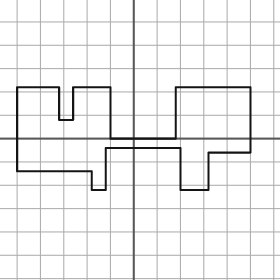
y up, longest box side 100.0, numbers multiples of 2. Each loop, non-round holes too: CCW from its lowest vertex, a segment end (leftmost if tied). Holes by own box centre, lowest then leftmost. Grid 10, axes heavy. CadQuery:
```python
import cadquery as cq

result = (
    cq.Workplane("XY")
    .moveTo(-18.0, -22.0)
    .lineTo(-12.0, -22.0)
    .lineTo(-12.0, -4.0)
    .lineTo(20.0, -4.0)
    .lineTo(20.0, -22.0)
    .lineTo(32.0, -22.0)
    .lineTo(32.0, -6.0)
    .lineTo(50.0, -6.0)
    .lineTo(50.0, 22.0)
    .lineTo(18.0, 22.0)
    .lineTo(18.0, 0.0)
    .lineTo(-10.0, 0.0)
    .lineTo(-10.0, 22.0)
    .lineTo(-26.0, 22.0)
    .lineTo(-26.0, 8.0)
    .lineTo(-32.0, 8.0)
    .lineTo(-32.0, 22.0)
    .lineTo(-50.0, 22.0)
    .lineTo(-50.0, -14.0)
    .lineTo(-18.0, -14.0)
    .close()
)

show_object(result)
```